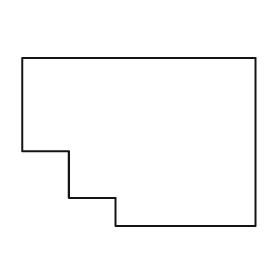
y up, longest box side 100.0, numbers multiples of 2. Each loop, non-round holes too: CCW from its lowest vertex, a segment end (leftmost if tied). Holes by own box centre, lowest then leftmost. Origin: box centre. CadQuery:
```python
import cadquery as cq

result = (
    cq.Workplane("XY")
    .moveTo(-10.0, -36.0)
    .lineTo(50.0, -36.0)
    .lineTo(50.0, 36.0)
    .lineTo(-50.0, 36.0)
    .lineTo(-50.0, -4.0)
    .lineTo(-30.0, -4.0)
    .lineTo(-30.0, -24.0)
    .lineTo(-10.0, -24.0)
    .close()
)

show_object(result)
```